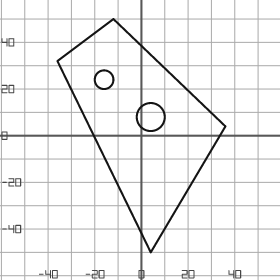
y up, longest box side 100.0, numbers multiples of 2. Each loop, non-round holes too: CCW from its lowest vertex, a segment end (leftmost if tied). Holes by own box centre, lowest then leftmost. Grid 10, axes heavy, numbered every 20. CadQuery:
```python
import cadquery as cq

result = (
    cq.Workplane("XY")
    .moveTo(4.0, -50.0)
    .lineTo(36.0, 4.0)
    .lineTo(-12.0, 50.0)
    .lineTo(-36.0, 32.0)
    .close()
    .moveTo(4.0, 8.0)
    .circle(6.0)
    .moveTo(-16.0, 24.0)
    .circle(4.0)
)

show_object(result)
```